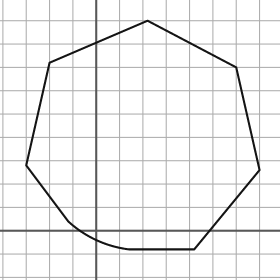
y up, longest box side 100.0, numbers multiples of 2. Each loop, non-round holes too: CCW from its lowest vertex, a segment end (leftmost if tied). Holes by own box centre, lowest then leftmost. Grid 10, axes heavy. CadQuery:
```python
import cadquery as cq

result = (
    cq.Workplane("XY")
    .moveTo(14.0, -8.0)
    .lineTo(42.0, -8.0)
    .lineTo(70.0, 26.0)
    .lineTo(60.0, 70.0)
    .lineTo(22.0, 90.0)
    .lineTo(-20.0, 72.0)
    .lineTo(-30.0, 28.0)
    .lineTo(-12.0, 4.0)
    .threePointArc((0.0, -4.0), (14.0, -8.0))
    .close()
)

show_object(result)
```